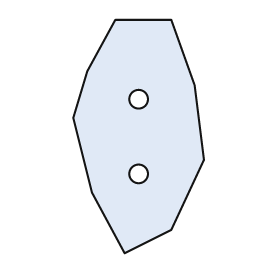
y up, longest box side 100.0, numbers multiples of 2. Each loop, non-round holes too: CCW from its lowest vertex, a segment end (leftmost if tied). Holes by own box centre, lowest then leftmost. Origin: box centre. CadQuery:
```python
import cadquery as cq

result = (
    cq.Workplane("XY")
    .moveTo(-6.0, -50.0)
    .lineTo(14.0, -40.0)
    .lineTo(28.0, -10.0)
    .lineTo(24.0, 22.0)
    .lineTo(14.0, 50.0)
    .lineTo(-10.0, 50.0)
    .lineTo(-22.0, 28.0)
    .lineTo(-28.0, 8.0)
    .lineTo(-20.0, -24.0)
    .close()
    .moveTo(0.0, -16.0)
    .circle(4.0)
    .moveTo(0.0, 16.0)
    .circle(4.0)
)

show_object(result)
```